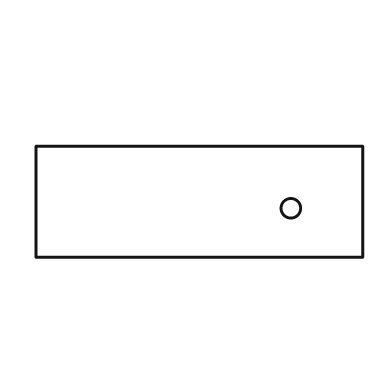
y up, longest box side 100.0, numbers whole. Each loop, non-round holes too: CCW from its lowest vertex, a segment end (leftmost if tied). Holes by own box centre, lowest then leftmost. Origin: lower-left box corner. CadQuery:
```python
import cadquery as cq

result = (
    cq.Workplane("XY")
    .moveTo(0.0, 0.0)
    .lineTo(100.0, 0.0)
    .lineTo(100.0, 34.0)
    .lineTo(0.0, 34.0)
    .close()
    .moveTo(78.0, 15.0)
    .circle(3.0)
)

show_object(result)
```